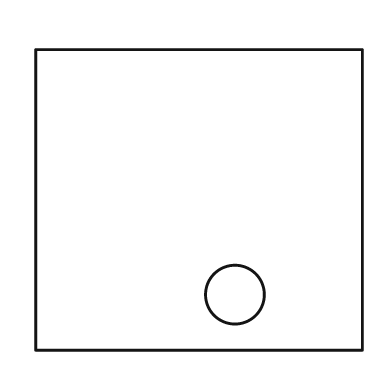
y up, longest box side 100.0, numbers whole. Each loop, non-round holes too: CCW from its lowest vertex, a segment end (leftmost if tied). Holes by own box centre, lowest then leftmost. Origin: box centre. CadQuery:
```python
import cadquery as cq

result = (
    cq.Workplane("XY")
    .moveTo(-50.0, -46.0)
    .lineTo(50.0, -46.0)
    .lineTo(50.0, 46.0)
    .lineTo(-50.0, 46.0)
    .close()
    .moveTo(11.0, -29.0)
    .circle(9.0)
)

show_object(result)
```